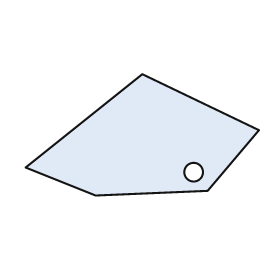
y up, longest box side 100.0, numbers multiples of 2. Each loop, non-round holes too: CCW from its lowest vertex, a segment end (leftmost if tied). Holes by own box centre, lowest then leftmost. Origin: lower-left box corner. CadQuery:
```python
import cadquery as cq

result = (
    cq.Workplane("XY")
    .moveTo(30.0, 0.0)
    .lineTo(78.0, 2.0)
    .lineTo(100.0, 28.0)
    .lineTo(50.0, 52.0)
    .lineTo(0.0, 12.0)
    .close()
    .moveTo(72.0, 10.0)
    .circle(4.0)
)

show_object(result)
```